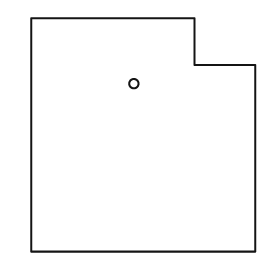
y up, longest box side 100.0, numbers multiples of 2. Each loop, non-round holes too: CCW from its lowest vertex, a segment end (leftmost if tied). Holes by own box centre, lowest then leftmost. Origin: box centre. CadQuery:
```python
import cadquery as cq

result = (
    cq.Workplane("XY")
    .moveTo(-48.0, -50.0)
    .lineTo(48.0, -50.0)
    .lineTo(48.0, 30.0)
    .lineTo(22.0, 30.0)
    .lineTo(22.0, 50.0)
    .lineTo(-48.0, 50.0)
    .close()
    .moveTo(-4.0, 22.0)
    .circle(2.0)
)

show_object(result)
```